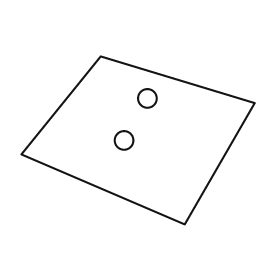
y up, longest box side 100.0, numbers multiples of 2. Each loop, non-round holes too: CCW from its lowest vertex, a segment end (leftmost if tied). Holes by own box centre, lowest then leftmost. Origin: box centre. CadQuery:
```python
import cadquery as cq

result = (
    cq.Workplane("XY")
    .moveTo(20.0, -36.0)
    .lineTo(50.0, 16.0)
    .lineTo(-16.0, 36.0)
    .lineTo(-50.0, -6.0)
    .close()
    .moveTo(-6.0, 0.0)
    .circle(4.0)
    .moveTo(4.0, 18.0)
    .circle(4.0)
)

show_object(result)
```